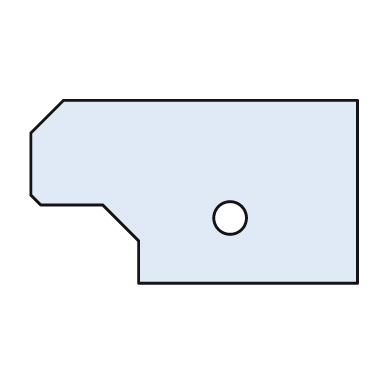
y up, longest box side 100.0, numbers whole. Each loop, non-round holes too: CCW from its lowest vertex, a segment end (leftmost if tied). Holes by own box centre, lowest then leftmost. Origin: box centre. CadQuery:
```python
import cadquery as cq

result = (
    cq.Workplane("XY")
    .moveTo(-17.0, -28.0)
    .lineTo(50.0, -28.0)
    .lineTo(50.0, 28.0)
    .lineTo(-40.0, 28.0)
    .lineTo(-50.0, 18.0)
    .lineTo(-50.0, -1.0)
    .lineTo(-47.0, -4.0)
    .lineTo(-28.0, -4.0)
    .lineTo(-17.0, -15.0)
    .close()
    .moveTo(11.0, -8.0)
    .circle(5.0)
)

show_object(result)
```